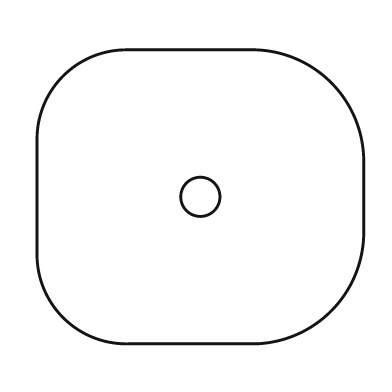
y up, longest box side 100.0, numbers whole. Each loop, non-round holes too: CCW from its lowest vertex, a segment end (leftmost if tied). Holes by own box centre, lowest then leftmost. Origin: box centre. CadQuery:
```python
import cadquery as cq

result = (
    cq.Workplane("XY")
    .moveTo(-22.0, -45.0)
    .lineTo(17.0, -45.0)
    .threePointArc((40.0, -35.0), (50.0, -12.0))
    .lineTo(50.0, 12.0)
    .threePointArc((40.0, 35.0), (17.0, 45.0))
    .lineTo(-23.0, 45.0)
    .threePointArc((-42.0, 37.0), (-50.0, 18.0))
    .lineTo(-50.0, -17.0)
    .threePointArc((-42.0, -37.0), (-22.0, -45.0))
    .close()
    .moveTo(0.0, 0.0)
    .circle(6.0)
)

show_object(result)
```